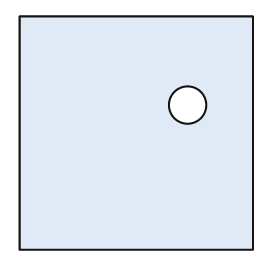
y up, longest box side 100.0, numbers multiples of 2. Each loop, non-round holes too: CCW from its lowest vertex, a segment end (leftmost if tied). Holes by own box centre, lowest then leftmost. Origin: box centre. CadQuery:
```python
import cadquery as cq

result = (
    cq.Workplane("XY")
    .moveTo(-50.0, -50.0)
    .lineTo(50.0, -50.0)
    .lineTo(50.0, 50.0)
    .lineTo(-50.0, 50.0)
    .close()
    .moveTo(22.0, 12.0)
    .circle(8.0)
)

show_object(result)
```